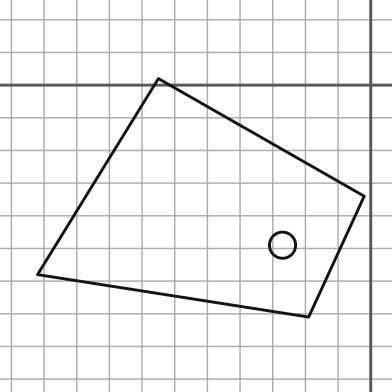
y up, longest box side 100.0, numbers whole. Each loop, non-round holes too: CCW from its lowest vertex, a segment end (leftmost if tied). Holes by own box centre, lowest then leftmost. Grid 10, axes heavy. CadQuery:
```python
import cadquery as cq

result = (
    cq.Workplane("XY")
    .moveTo(-19.0, -71.0)
    .lineTo(-2.0, -34.0)
    .lineTo(-65.0, 2.0)
    .lineTo(-102.0, -58.0)
    .close()
    .moveTo(-27.0, -49.0)
    .circle(4.0)
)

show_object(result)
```